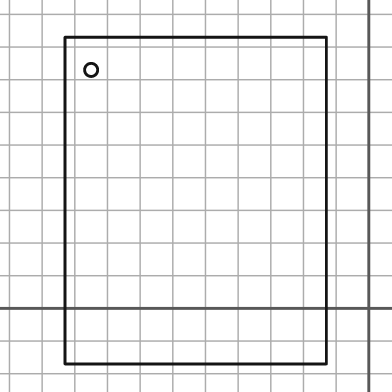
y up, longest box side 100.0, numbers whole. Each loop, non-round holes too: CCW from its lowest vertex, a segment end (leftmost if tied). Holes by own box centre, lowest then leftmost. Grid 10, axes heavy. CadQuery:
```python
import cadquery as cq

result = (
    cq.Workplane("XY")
    .moveTo(-93.0, -17.0)
    .lineTo(-13.0, -17.0)
    .lineTo(-13.0, 83.0)
    .lineTo(-93.0, 83.0)
    .close()
    .moveTo(-85.0, 73.0)
    .circle(2.0)
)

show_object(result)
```